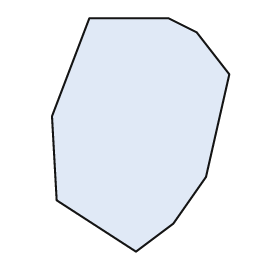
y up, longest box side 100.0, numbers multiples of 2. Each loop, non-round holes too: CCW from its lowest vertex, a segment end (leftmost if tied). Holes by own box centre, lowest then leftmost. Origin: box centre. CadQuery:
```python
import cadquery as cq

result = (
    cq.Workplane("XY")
    .moveTo(-2.0, -50.0)
    .lineTo(14.0, -38.0)
    .lineTo(28.0, -18.0)
    .lineTo(38.0, 26.0)
    .lineTo(24.0, 44.0)
    .lineTo(12.0, 50.0)
    .lineTo(-22.0, 50.0)
    .lineTo(-38.0, 8.0)
    .lineTo(-36.0, -28.0)
    .close()
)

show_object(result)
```